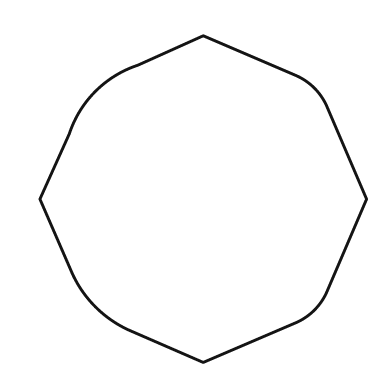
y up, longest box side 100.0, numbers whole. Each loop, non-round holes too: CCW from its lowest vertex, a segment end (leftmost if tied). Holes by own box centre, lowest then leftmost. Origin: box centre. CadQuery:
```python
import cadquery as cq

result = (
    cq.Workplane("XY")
    .moveTo(0.0, -50.0)
    .lineTo(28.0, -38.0)
    .threePointArc((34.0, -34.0), (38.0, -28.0))
    .lineTo(50.0, 0.0)
    .lineTo(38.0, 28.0)
    .threePointArc((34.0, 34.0), (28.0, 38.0))
    .lineTo(0.0, 50.0)
    .lineTo(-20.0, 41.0)
    .threePointArc((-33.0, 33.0), (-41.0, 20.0))
    .lineTo(-50.0, 0.0)
    .lineTo(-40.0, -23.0)
    .threePointArc((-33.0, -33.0), (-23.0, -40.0))
    .close()
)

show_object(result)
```